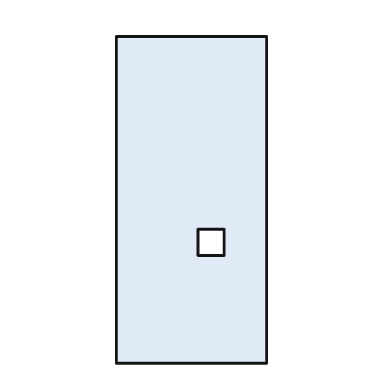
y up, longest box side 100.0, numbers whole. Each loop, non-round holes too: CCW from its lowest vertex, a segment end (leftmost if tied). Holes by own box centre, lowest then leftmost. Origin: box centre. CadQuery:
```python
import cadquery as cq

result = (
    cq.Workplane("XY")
    .moveTo(-23.0, -50.0)
    .lineTo(23.0, -50.0)
    .lineTo(23.0, 50.0)
    .lineTo(-23.0, 50.0)
    .close()
    .moveTo(2.0, -17.0)
    .lineTo(10.0, -17.0)
    .lineTo(10.0, -9.0)
    .lineTo(2.0, -9.0)
    .close()
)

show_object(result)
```